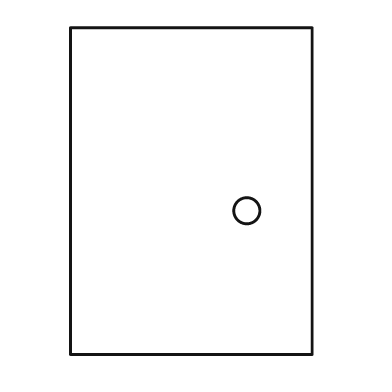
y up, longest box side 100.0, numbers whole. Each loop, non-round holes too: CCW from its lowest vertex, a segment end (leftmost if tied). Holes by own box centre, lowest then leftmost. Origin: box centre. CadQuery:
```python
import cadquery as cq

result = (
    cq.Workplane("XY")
    .moveTo(-37.0, -50.0)
    .lineTo(37.0, -50.0)
    .lineTo(37.0, 50.0)
    .lineTo(-37.0, 50.0)
    .close()
    .moveTo(17.0, -6.0)
    .circle(4.0)
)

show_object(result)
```